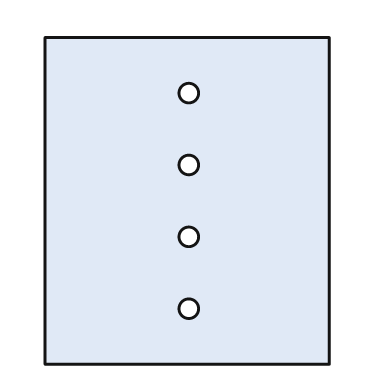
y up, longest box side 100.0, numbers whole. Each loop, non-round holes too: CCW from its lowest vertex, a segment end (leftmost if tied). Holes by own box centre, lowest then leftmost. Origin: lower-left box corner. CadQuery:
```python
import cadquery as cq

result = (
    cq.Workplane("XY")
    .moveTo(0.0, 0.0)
    .lineTo(87.0, 0.0)
    .lineTo(87.0, 100.0)
    .lineTo(0.0, 100.0)
    .close()
    .moveTo(44.0, 17.0)
    .circle(3.0)
    .moveTo(44.0, 39.0)
    .circle(3.0)
    .moveTo(44.0, 61.0)
    .circle(3.0)
    .moveTo(44.0, 83.0)
    .circle(3.0)
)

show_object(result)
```